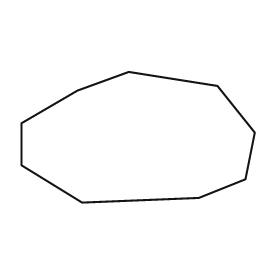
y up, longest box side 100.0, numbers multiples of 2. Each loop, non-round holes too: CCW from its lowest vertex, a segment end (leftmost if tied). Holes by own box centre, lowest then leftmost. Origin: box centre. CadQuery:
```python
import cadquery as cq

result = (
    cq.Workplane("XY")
    .moveTo(-24.0, -28.0)
    .lineTo(26.0, -26.0)
    .lineTo(46.0, -18.0)
    .lineTo(50.0, 2.0)
    .lineTo(34.0, 22.0)
    .lineTo(-4.0, 28.0)
    .lineTo(-26.0, 20.0)
    .lineTo(-50.0, 6.0)
    .lineTo(-50.0, -12.0)
    .close()
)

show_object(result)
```